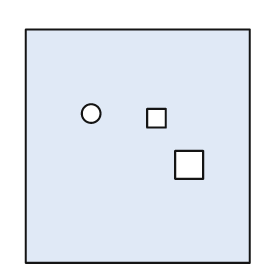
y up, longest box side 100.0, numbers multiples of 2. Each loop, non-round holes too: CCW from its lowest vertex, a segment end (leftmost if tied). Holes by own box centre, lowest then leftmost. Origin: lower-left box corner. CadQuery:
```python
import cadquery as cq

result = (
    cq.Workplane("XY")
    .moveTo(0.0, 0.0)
    .lineTo(96.0, 0.0)
    .lineTo(96.0, 100.0)
    .lineTo(0.0, 100.0)
    .close()
    .moveTo(64.0, 36.0)
    .lineTo(76.0, 36.0)
    .lineTo(76.0, 48.0)
    .lineTo(64.0, 48.0)
    .close()
    .moveTo(52.0, 58.0)
    .lineTo(60.0, 58.0)
    .lineTo(60.0, 66.0)
    .lineTo(52.0, 66.0)
    .close()
    .moveTo(28.0, 64.0)
    .circle(4.0)
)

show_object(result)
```